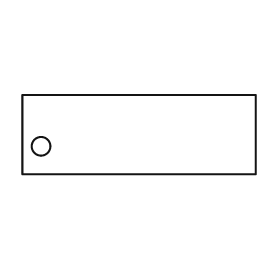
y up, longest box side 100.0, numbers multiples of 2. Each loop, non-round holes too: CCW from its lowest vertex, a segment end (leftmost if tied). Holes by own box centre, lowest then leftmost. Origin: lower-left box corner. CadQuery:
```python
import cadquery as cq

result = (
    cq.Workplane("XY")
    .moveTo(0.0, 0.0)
    .lineTo(100.0, 0.0)
    .lineTo(100.0, 34.0)
    .lineTo(0.0, 34.0)
    .close()
    .moveTo(8.0, 12.0)
    .circle(4.0)
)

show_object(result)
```